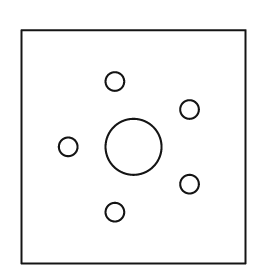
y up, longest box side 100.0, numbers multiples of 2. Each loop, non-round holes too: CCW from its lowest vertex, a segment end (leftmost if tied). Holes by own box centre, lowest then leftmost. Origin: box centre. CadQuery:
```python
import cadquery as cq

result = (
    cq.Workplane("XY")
    .moveTo(-48.0, -50.0)
    .lineTo(48.0, -50.0)
    .lineTo(48.0, 50.0)
    .lineTo(-48.0, 50.0)
    .close()
    .moveTo(-8.0, -28.0)
    .circle(4.0)
    .moveTo(24.0, -16.0)
    .circle(4.0)
    .moveTo(-28.0, 0.0)
    .circle(4.0)
    .moveTo(0.0, 0.0)
    .circle(12.0)
    .moveTo(24.0, 16.0)
    .circle(4.0)
    .moveTo(-8.0, 28.0)
    .circle(4.0)
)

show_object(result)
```